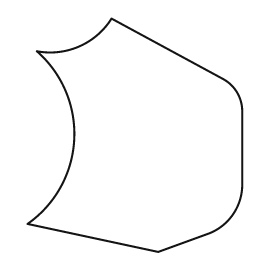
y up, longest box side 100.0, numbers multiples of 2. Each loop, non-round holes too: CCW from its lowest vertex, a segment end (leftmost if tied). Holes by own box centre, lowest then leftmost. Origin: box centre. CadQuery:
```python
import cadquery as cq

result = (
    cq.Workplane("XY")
    .moveTo(10.0, -50.0)
    .lineTo(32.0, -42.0)
    .threePointArc((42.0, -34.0), (46.0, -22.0))
    .lineTo(46.0, 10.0)
    .threePointArc((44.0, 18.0), (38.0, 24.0))
    .lineTo(-10.0, 50.0)
    .threePointArc((-24.0, 38.0), (-42.0, 36.0))
    .threePointArc((-26.0, -2.0), (-46.0, -38.0))
    .close()
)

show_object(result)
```